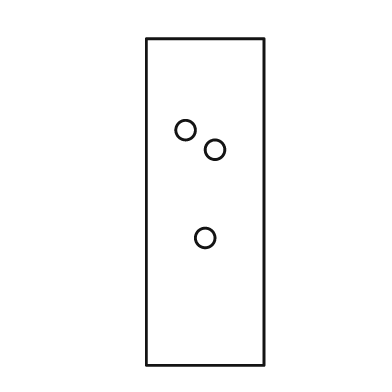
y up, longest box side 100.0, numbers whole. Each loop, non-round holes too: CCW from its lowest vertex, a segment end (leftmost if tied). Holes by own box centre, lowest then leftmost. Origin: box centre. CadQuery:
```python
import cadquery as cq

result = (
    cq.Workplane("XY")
    .moveTo(-18.0, -50.0)
    .lineTo(18.0, -50.0)
    .lineTo(18.0, 50.0)
    .lineTo(-18.0, 50.0)
    .close()
    .moveTo(0.0, -11.0)
    .circle(3.0)
    .moveTo(3.0, 16.0)
    .circle(3.0)
    .moveTo(-6.0, 22.0)
    .circle(3.0)
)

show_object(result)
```